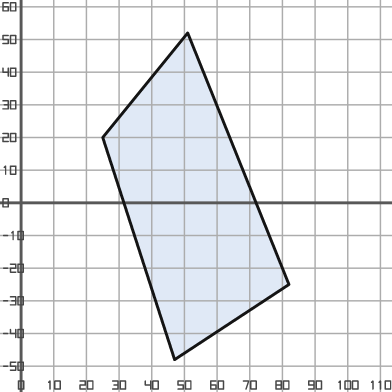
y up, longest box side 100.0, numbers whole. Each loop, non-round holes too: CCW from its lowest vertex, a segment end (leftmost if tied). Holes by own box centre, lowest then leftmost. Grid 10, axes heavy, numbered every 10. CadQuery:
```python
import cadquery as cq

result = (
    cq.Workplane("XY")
    .moveTo(47.0, -48.0)
    .lineTo(82.0, -25.0)
    .lineTo(51.0, 52.0)
    .lineTo(25.0, 20.0)
    .close()
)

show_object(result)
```